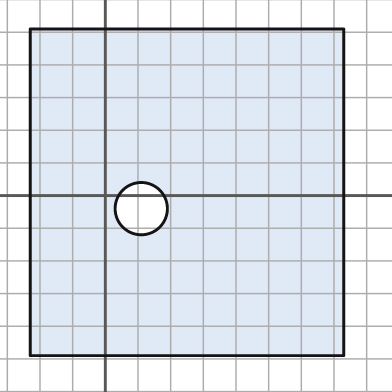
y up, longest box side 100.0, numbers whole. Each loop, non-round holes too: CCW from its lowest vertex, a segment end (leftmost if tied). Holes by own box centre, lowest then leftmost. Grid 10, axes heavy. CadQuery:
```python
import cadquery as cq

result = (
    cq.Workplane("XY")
    .moveTo(-23.0, -49.0)
    .lineTo(73.0, -49.0)
    .lineTo(73.0, 51.0)
    .lineTo(-23.0, 51.0)
    .close()
    .moveTo(11.0, -4.0)
    .circle(8.0)
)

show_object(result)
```